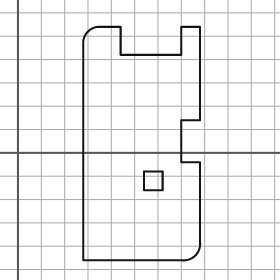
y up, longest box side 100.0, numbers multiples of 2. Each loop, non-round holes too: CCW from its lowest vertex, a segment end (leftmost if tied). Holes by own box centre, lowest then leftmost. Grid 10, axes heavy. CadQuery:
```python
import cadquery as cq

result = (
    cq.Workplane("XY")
    .moveTo(28.0, -46.0)
    .lineTo(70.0, -46.0)
    .threePointArc((76.0, -44.0), (78.0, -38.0))
    .lineTo(78.0, -4.0)
    .lineTo(70.0, -4.0)
    .lineTo(70.0, 14.0)
    .lineTo(78.0, 14.0)
    .lineTo(78.0, 54.0)
    .lineTo(70.0, 54.0)
    .lineTo(70.0, 42.0)
    .lineTo(44.0, 42.0)
    .lineTo(44.0, 54.0)
    .lineTo(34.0, 54.0)
    .threePointArc((30.0, 52.0), (28.0, 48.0))
    .close()
    .moveTo(54.0, -16.0)
    .lineTo(62.0, -16.0)
    .lineTo(62.0, -8.0)
    .lineTo(54.0, -8.0)
    .close()
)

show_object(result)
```